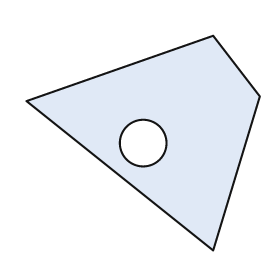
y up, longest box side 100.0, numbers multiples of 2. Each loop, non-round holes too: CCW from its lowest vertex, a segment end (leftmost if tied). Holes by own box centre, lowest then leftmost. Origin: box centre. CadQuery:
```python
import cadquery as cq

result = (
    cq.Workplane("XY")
    .moveTo(30.0, -46.0)
    .lineTo(50.0, 20.0)
    .lineTo(30.0, 46.0)
    .lineTo(-50.0, 18.0)
    .close()
    .moveTo(0.0, 0.0)
    .circle(10.0)
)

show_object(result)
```